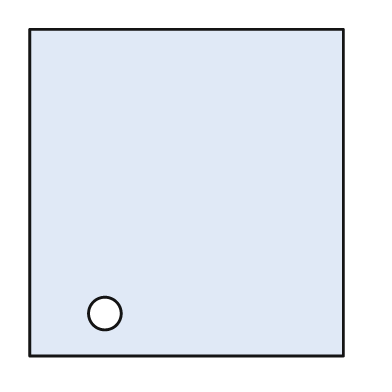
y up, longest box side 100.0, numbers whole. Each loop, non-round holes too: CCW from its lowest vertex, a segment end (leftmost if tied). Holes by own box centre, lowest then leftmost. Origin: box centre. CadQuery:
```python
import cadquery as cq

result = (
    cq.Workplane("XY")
    .moveTo(-48.0, -50.0)
    .lineTo(48.0, -50.0)
    .lineTo(48.0, 50.0)
    .lineTo(-48.0, 50.0)
    .close()
    .moveTo(-25.0, -37.0)
    .circle(5.0)
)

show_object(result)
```